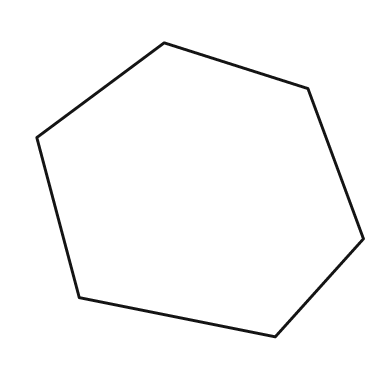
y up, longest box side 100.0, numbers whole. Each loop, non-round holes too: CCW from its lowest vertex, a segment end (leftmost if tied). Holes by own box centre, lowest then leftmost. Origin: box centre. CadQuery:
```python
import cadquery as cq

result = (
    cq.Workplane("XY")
    .moveTo(23.0, -45.0)
    .lineTo(50.0, -15.0)
    .lineTo(33.0, 31.0)
    .lineTo(-11.0, 45.0)
    .lineTo(-50.0, 16.0)
    .lineTo(-37.0, -33.0)
    .close()
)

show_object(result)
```